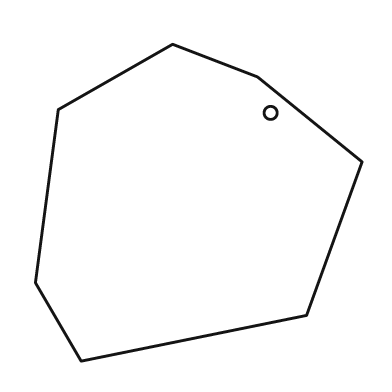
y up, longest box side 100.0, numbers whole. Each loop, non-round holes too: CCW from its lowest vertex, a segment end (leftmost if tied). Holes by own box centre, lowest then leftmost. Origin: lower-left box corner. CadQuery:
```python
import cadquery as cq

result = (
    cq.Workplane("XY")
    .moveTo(14.0, 0.0)
    .lineTo(83.0, 14.0)
    .lineTo(100.0, 61.0)
    .lineTo(68.0, 87.0)
    .lineTo(42.0, 97.0)
    .lineTo(7.0, 77.0)
    .lineTo(0.0, 24.0)
    .close()
    .moveTo(72.0, 76.0)
    .circle(2.0)
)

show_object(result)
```